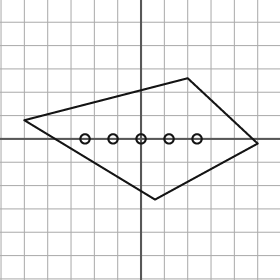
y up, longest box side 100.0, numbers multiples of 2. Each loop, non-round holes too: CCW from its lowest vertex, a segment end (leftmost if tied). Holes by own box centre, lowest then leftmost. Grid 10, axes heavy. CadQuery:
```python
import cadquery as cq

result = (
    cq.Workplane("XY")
    .moveTo(6.0, -26.0)
    .lineTo(50.0, -2.0)
    .lineTo(20.0, 26.0)
    .lineTo(-50.0, 8.0)
    .close()
    .moveTo(-24.0, 0.0)
    .circle(2.0)
    .moveTo(-12.0, 0.0)
    .circle(2.0)
    .moveTo(0.0, 0.0)
    .circle(2.0)
    .moveTo(12.0, 0.0)
    .circle(2.0)
    .moveTo(24.0, 0.0)
    .circle(2.0)
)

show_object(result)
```